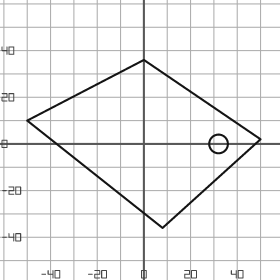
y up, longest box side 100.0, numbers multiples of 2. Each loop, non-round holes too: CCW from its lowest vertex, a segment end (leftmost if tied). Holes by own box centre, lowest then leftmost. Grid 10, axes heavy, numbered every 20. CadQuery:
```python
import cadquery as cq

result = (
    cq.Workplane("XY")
    .moveTo(8.0, -36.0)
    .lineTo(50.0, 2.0)
    .lineTo(0.0, 36.0)
    .lineTo(-50.0, 10.0)
    .close()
    .moveTo(32.0, 0.0)
    .circle(4.0)
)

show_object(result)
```